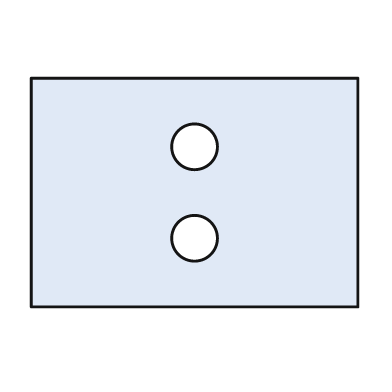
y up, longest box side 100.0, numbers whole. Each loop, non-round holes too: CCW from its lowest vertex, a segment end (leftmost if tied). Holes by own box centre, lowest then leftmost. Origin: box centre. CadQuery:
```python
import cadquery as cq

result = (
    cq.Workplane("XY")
    .moveTo(-50.0, -35.0)
    .lineTo(50.0, -35.0)
    .lineTo(50.0, 35.0)
    .lineTo(-50.0, 35.0)
    .close()
    .moveTo(0.0, -14.0)
    .circle(7.0)
    .moveTo(0.0, 14.0)
    .circle(7.0)
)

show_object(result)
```